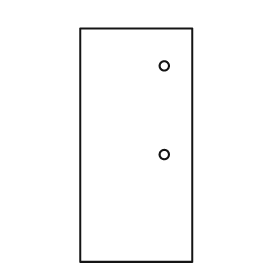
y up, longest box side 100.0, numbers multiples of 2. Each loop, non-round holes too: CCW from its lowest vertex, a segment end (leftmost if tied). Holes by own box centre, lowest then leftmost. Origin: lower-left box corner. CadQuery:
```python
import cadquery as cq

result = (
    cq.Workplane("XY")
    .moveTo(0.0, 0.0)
    .lineTo(48.0, 0.0)
    .lineTo(48.0, 100.0)
    .lineTo(0.0, 100.0)
    .close()
    .moveTo(36.0, 46.0)
    .circle(2.0)
    .moveTo(36.0, 84.0)
    .circle(2.0)
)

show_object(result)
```